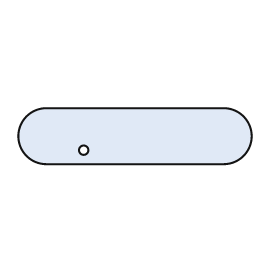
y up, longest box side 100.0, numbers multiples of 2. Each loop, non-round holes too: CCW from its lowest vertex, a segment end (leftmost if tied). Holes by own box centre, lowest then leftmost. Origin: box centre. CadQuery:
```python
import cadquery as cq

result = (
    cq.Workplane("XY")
    .moveTo(-38.0, -12.0)
    .lineTo(38.0, -12.0)
    .threePointArc((50.0, 0.0), (38.0, 12.0))
    .lineTo(-38.0, 12.0)
    .threePointArc((-50.0, 0.0), (-38.0, -12.0))
    .close()
    .moveTo(-22.0, -6.0)
    .circle(2.0)
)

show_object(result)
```